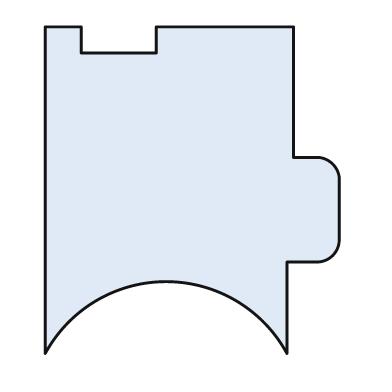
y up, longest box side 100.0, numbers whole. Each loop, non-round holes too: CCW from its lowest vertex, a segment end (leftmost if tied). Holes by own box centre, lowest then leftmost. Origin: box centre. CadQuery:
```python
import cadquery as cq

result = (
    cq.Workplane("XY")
    .moveTo(-45.0, -50.0)
    .threePointArc((-8.0, -28.0), (29.0, -50.0))
    .lineTo(29.0, -22.0)
    .lineTo(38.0, -22.0)
    .threePointArc((43.0, -20.0), (45.0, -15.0))
    .lineTo(45.0, 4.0)
    .threePointArc((43.0, 8.0), (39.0, 10.0))
    .lineTo(31.0, 10.0)
    .lineTo(31.0, 50.0)
    .lineTo(-11.0, 50.0)
    .lineTo(-11.0, 42.0)
    .lineTo(-34.0, 42.0)
    .lineTo(-34.0, 50.0)
    .lineTo(-45.0, 50.0)
    .close()
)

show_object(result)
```